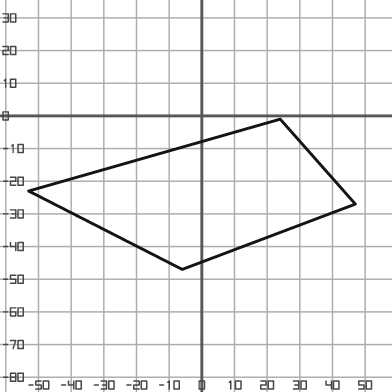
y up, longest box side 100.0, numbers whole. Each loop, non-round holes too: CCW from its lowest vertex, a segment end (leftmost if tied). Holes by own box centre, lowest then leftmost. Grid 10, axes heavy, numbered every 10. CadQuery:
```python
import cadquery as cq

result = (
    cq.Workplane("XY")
    .moveTo(-6.0, -47.0)
    .lineTo(47.0, -27.0)
    .lineTo(24.0, -1.0)
    .lineTo(-53.0, -23.0)
    .close()
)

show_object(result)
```